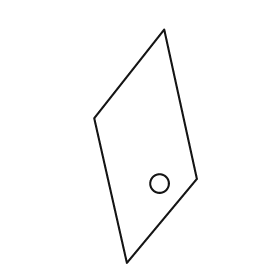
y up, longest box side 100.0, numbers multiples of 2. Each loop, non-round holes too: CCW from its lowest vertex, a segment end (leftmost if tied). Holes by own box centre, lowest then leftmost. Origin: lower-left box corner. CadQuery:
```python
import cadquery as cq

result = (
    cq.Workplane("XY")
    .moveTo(14.0, 0.0)
    .lineTo(44.0, 36.0)
    .lineTo(30.0, 100.0)
    .lineTo(0.0, 62.0)
    .close()
    .moveTo(28.0, 34.0)
    .circle(4.0)
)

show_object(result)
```